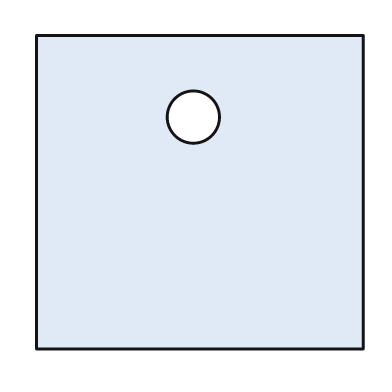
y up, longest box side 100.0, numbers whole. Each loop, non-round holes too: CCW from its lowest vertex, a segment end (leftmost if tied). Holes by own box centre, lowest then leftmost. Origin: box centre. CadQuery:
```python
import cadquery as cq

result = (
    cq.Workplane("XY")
    .moveTo(-50.0, -48.0)
    .lineTo(50.0, -48.0)
    .lineTo(50.0, 48.0)
    .lineTo(-50.0, 48.0)
    .close()
    .moveTo(-2.0, 23.0)
    .circle(8.0)
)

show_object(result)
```